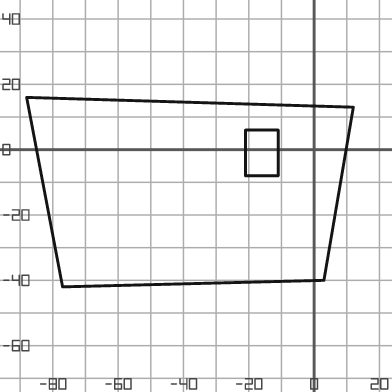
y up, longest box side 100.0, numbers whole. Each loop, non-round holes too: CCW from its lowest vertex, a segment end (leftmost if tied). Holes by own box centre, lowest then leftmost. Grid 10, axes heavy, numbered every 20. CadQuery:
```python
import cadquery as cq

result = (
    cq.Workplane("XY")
    .moveTo(-77.0, -42.0)
    .lineTo(3.0, -40.0)
    .lineTo(12.0, 13.0)
    .lineTo(-88.0, 16.0)
    .close()
    .moveTo(-21.0, -8.0)
    .lineTo(-11.0, -8.0)
    .lineTo(-11.0, 6.0)
    .lineTo(-21.0, 6.0)
    .close()
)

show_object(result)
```